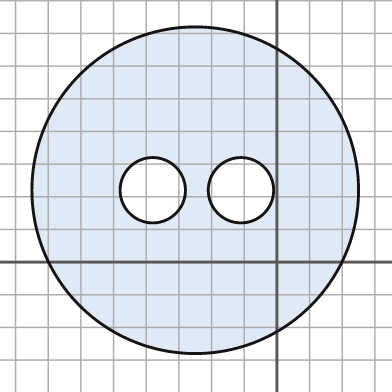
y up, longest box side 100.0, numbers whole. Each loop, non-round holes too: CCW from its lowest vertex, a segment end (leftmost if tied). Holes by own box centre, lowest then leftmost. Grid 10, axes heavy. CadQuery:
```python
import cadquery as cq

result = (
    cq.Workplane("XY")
    .moveTo(-25.0, 22.0)
    .circle(50.0)
    .moveTo(-38.0, 22.0)
    .circle(10.0)
    .moveTo(-11.0, 22.0)
    .circle(10.0)
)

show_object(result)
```